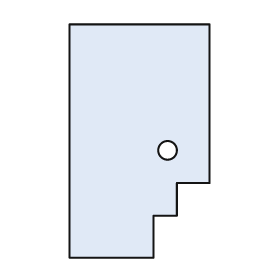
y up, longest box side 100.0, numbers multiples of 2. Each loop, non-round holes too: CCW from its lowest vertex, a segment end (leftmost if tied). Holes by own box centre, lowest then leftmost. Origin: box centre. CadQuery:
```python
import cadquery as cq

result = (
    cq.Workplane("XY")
    .moveTo(-30.0, -50.0)
    .lineTo(6.0, -50.0)
    .lineTo(6.0, -32.0)
    .lineTo(16.0, -32.0)
    .lineTo(16.0, -18.0)
    .lineTo(30.0, -18.0)
    .lineTo(30.0, 50.0)
    .lineTo(-30.0, 50.0)
    .close()
    .moveTo(12.0, -4.0)
    .circle(4.0)
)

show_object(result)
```